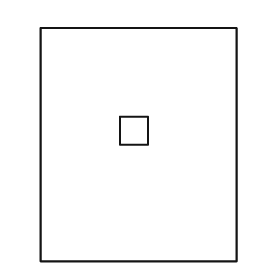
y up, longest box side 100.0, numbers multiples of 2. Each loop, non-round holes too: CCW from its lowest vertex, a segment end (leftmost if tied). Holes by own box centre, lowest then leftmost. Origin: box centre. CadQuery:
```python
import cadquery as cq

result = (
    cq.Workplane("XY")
    .moveTo(-42.0, -50.0)
    .lineTo(42.0, -50.0)
    .lineTo(42.0, 50.0)
    .lineTo(-42.0, 50.0)
    .close()
    .moveTo(-8.0, 0.0)
    .lineTo(4.0, 0.0)
    .lineTo(4.0, 12.0)
    .lineTo(-8.0, 12.0)
    .close()
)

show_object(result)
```